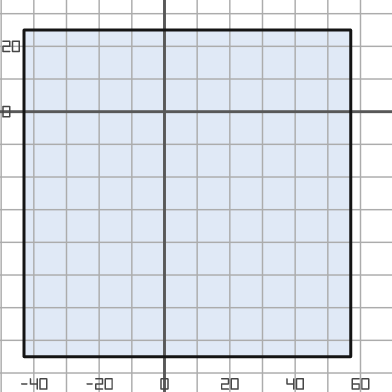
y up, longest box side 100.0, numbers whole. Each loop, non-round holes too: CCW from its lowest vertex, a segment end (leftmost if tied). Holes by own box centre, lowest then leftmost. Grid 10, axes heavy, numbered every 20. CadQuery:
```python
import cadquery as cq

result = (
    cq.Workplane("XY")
    .moveTo(-43.0, -75.0)
    .lineTo(57.0, -75.0)
    .lineTo(57.0, 25.0)
    .lineTo(-43.0, 25.0)
    .close()
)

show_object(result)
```